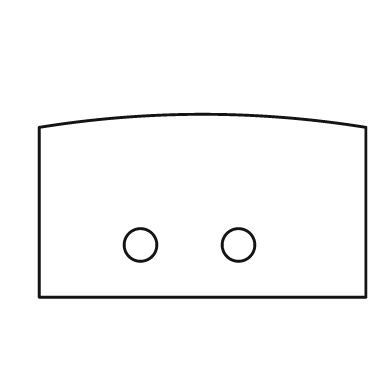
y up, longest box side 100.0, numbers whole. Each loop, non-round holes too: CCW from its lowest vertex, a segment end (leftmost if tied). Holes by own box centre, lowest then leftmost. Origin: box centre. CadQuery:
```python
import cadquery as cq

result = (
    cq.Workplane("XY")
    .moveTo(-50.0, -28.0)
    .lineTo(50.0, -28.0)
    .lineTo(50.0, 24.0)
    .threePointArc((0.0, 28.0), (-50.0, 24.0))
    .close()
    .moveTo(-19.0, -12.0)
    .circle(5.0)
    .moveTo(11.0, -12.0)
    .circle(5.0)
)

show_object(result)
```